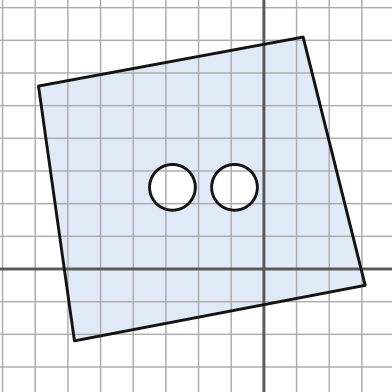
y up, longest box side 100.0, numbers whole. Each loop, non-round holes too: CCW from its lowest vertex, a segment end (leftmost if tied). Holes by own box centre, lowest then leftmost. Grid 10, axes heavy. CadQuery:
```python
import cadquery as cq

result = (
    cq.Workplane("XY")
    .moveTo(-58.0, -22.0)
    .lineTo(31.0, -5.0)
    .lineTo(12.0, 71.0)
    .lineTo(-69.0, 56.0)
    .close()
    .moveTo(-28.0, 25.0)
    .circle(7.0)
    .moveTo(-9.0, 25.0)
    .circle(7.0)
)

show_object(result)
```